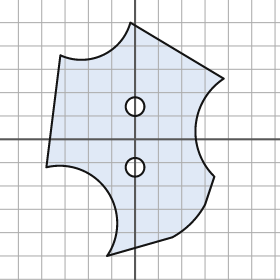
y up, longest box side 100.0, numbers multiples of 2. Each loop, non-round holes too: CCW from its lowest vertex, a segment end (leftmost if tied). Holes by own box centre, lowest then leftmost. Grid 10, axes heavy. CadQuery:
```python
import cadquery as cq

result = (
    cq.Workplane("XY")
    .moveTo(-12.0, -50.0)
    .lineTo(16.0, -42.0)
    .threePointArc((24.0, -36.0), (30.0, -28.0))
    .lineTo(34.0, -16.0)
    .threePointArc((26.0, 6.0), (38.0, 26.0))
    .lineTo(-2.0, 50.0)
    .threePointArc((-14.0, 36.0), (-32.0, 36.0))
    .lineTo(-38.0, -12.0)
    .threePointArc((-12.0, -22.0), (-12.0, -50.0))
    .close()
    .moveTo(0.0, -12.0)
    .circle(4.0)
    .moveTo(0.0, 14.0)
    .circle(4.0)
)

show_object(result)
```